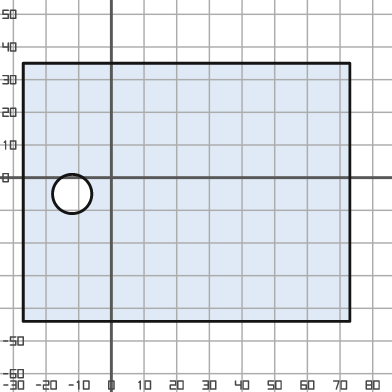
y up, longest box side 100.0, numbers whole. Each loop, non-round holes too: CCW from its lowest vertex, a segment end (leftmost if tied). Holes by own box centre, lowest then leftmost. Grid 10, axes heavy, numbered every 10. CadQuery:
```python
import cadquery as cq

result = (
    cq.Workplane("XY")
    .moveTo(-27.0, -44.0)
    .lineTo(73.0, -44.0)
    .lineTo(73.0, 35.0)
    .lineTo(-27.0, 35.0)
    .close()
    .moveTo(-12.0, -5.0)
    .circle(6.0)
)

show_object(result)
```